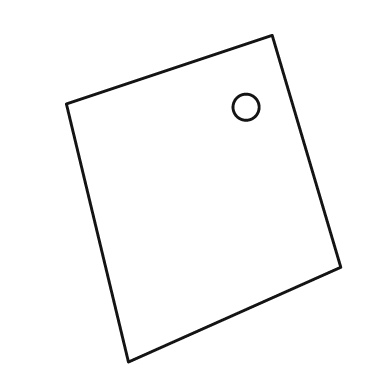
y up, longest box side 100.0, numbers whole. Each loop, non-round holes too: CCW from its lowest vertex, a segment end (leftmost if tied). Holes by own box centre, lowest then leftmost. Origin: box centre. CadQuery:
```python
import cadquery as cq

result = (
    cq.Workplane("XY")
    .moveTo(-23.0, -50.0)
    .lineTo(42.0, -21.0)
    .lineTo(21.0, 50.0)
    .lineTo(-42.0, 29.0)
    .close()
    .moveTo(13.0, 28.0)
    .circle(4.0)
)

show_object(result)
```